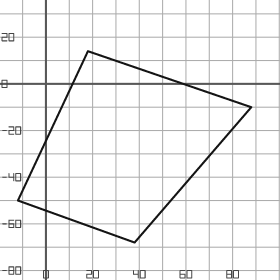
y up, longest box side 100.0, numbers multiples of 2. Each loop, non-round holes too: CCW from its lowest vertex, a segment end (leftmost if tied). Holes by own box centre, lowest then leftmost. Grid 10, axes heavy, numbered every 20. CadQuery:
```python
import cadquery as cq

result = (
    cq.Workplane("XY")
    .moveTo(38.0, -68.0)
    .lineTo(88.0, -10.0)
    .lineTo(18.0, 14.0)
    .lineTo(-12.0, -50.0)
    .close()
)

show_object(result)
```